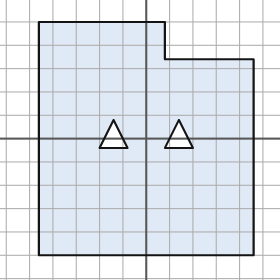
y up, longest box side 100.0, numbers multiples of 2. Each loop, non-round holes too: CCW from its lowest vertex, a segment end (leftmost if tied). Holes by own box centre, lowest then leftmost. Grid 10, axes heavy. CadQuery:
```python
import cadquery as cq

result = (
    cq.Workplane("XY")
    .moveTo(-46.0, -50.0)
    .lineTo(46.0, -50.0)
    .lineTo(46.0, 34.0)
    .lineTo(8.0, 34.0)
    .lineTo(8.0, 50.0)
    .lineTo(-46.0, 50.0)
    .close()
    .moveTo(-20.0, -4.0)
    .lineTo(-8.0, -4.0)
    .lineTo(-14.0, 8.0)
    .close()
    .moveTo(8.0, -4.0)
    .lineTo(20.0, -4.0)
    .lineTo(14.0, 8.0)
    .close()
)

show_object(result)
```